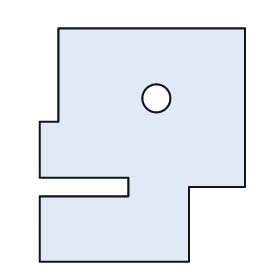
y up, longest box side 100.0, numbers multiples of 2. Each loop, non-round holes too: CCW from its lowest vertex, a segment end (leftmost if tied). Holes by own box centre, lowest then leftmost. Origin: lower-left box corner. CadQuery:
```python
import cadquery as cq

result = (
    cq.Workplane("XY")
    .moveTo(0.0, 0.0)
    .lineTo(64.0, 0.0)
    .lineTo(64.0, 32.0)
    .lineTo(88.0, 32.0)
    .lineTo(88.0, 100.0)
    .lineTo(8.0, 100.0)
    .lineTo(8.0, 60.0)
    .lineTo(0.0, 60.0)
    .lineTo(0.0, 36.0)
    .lineTo(38.0, 36.0)
    .lineTo(38.0, 28.0)
    .lineTo(0.0, 28.0)
    .close()
    .moveTo(50.0, 70.0)
    .circle(6.0)
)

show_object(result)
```